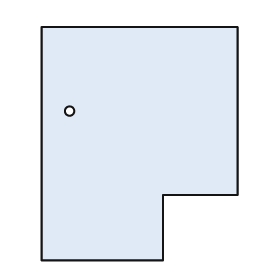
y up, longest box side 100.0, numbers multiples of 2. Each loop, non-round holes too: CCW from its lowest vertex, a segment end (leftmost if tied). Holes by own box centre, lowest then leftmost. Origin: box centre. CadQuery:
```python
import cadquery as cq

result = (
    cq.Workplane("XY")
    .moveTo(-42.0, -50.0)
    .lineTo(10.0, -50.0)
    .lineTo(10.0, -22.0)
    .lineTo(42.0, -22.0)
    .lineTo(42.0, 50.0)
    .lineTo(-42.0, 50.0)
    .close()
    .moveTo(-30.0, 14.0)
    .circle(2.0)
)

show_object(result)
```